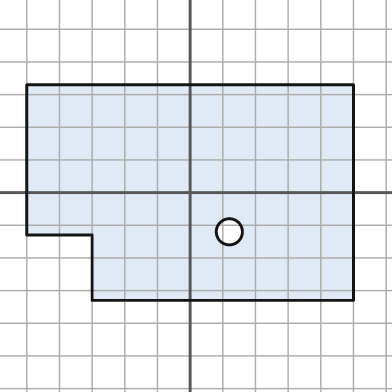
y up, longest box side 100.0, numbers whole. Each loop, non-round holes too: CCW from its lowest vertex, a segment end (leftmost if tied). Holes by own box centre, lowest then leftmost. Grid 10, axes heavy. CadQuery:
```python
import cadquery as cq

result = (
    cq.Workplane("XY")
    .moveTo(-30.0, -33.0)
    .lineTo(50.0, -33.0)
    .lineTo(50.0, 33.0)
    .lineTo(-50.0, 33.0)
    .lineTo(-50.0, -13.0)
    .lineTo(-30.0, -13.0)
    .close()
    .moveTo(12.0, -12.0)
    .circle(4.0)
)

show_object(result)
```